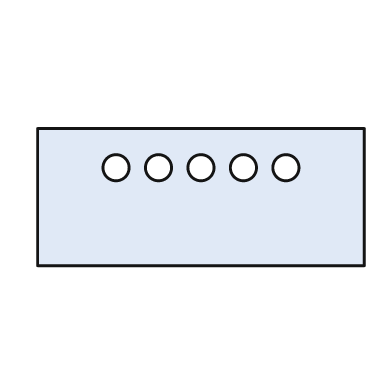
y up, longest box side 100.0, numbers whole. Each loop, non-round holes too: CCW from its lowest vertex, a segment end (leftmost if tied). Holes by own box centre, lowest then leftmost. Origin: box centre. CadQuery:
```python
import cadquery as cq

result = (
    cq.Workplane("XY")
    .moveTo(-50.0, -21.0)
    .lineTo(50.0, -21.0)
    .lineTo(50.0, 21.0)
    .lineTo(-50.0, 21.0)
    .close()
    .moveTo(-26.0, 9.0)
    .circle(4.0)
    .moveTo(-13.0, 9.0)
    .circle(4.0)
    .moveTo(0.0, 9.0)
    .circle(4.0)
    .moveTo(13.0, 9.0)
    .circle(4.0)
    .moveTo(26.0, 9.0)
    .circle(4.0)
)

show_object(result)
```